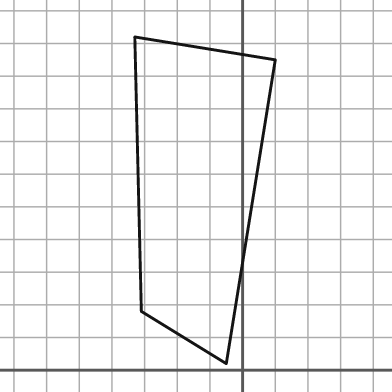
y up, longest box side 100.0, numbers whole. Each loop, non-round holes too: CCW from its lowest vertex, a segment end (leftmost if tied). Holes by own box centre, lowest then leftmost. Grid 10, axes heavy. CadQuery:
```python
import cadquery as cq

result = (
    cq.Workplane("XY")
    .moveTo(-5.0, 2.0)
    .lineTo(10.0, 95.0)
    .lineTo(-33.0, 102.0)
    .lineTo(-31.0, 18.0)
    .close()
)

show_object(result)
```